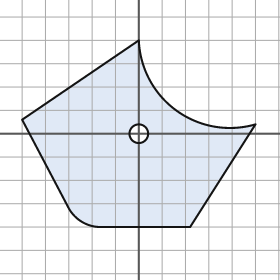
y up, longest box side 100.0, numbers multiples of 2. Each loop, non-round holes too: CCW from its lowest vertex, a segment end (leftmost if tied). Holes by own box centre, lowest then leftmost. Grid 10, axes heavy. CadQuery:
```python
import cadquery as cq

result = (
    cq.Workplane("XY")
    .moveTo(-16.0, -40.0)
    .lineTo(22.0, -40.0)
    .lineTo(50.0, 4.0)
    .threePointArc((16.0, 10.0), (0.0, 40.0))
    .lineTo(-50.0, 6.0)
    .lineTo(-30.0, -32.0)
    .threePointArc((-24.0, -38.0), (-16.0, -40.0))
    .close()
    .moveTo(0.0, 0.0)
    .circle(4.0)
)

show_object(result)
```